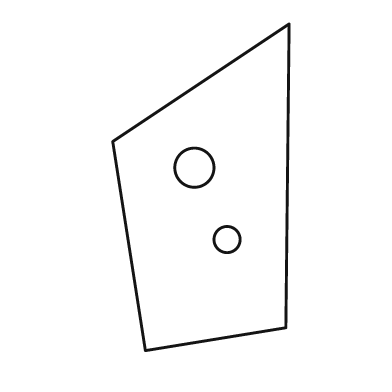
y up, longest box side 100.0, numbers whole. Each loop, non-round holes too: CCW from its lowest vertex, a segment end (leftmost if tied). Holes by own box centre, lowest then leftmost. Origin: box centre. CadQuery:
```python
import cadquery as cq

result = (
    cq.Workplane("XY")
    .moveTo(-17.0, -50.0)
    .lineTo(26.0, -43.0)
    .lineTo(27.0, 50.0)
    .lineTo(-27.0, 14.0)
    .close()
    .moveTo(8.0, -16.0)
    .circle(4.0)
    .moveTo(-2.0, 6.0)
    .circle(6.0)
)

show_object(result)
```